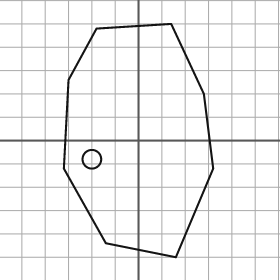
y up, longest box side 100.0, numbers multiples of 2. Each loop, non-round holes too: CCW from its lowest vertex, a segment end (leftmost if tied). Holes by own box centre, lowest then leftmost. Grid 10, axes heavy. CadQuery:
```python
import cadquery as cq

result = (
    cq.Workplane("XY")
    .moveTo(16.0, -50.0)
    .lineTo(32.0, -12.0)
    .lineTo(28.0, 20.0)
    .lineTo(14.0, 50.0)
    .lineTo(-18.0, 48.0)
    .lineTo(-30.0, 26.0)
    .lineTo(-32.0, -12.0)
    .lineTo(-14.0, -44.0)
    .close()
    .moveTo(-20.0, -8.0)
    .circle(4.0)
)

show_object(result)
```